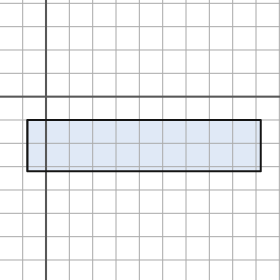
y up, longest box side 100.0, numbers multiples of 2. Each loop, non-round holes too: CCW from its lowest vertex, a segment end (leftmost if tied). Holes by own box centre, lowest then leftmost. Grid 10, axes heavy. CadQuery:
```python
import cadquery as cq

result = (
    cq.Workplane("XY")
    .moveTo(-8.0, -32.0)
    .lineTo(92.0, -32.0)
    .lineTo(92.0, -10.0)
    .lineTo(-8.0, -10.0)
    .close()
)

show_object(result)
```